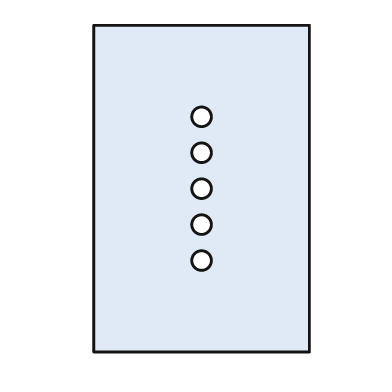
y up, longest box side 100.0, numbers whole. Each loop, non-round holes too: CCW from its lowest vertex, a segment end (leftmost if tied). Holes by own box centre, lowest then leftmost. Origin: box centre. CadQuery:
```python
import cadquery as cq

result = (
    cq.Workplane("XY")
    .moveTo(-33.0, -50.0)
    .lineTo(33.0, -50.0)
    .lineTo(33.0, 50.0)
    .lineTo(-33.0, 50.0)
    .close()
    .moveTo(0.0, -22.0)
    .circle(3.0)
    .moveTo(0.0, -11.0)
    .circle(3.0)
    .moveTo(0.0, 0.0)
    .circle(3.0)
    .moveTo(0.0, 11.0)
    .circle(3.0)
    .moveTo(0.0, 22.0)
    .circle(3.0)
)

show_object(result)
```